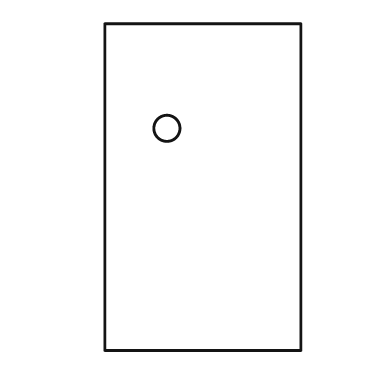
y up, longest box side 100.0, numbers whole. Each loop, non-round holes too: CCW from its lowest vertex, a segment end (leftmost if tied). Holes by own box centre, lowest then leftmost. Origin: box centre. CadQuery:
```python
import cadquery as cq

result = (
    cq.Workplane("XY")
    .moveTo(-30.0, -50.0)
    .lineTo(30.0, -50.0)
    .lineTo(30.0, 50.0)
    .lineTo(-30.0, 50.0)
    .close()
    .moveTo(-11.0, 18.0)
    .circle(4.0)
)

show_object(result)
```